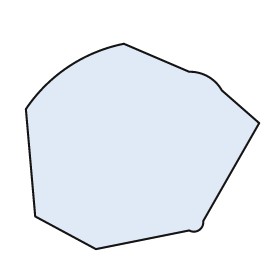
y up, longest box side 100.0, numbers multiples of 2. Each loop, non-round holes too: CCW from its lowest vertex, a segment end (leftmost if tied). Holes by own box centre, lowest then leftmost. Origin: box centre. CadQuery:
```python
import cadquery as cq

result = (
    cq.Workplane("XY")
    .moveTo(-20.0, -44.0)
    .lineTo(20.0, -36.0)
    .threePointArc((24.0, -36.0), (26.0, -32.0))
    .lineTo(50.0, 10.0)
    .lineTo(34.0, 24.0)
    .threePointArc((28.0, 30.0), (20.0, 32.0))
    .lineTo(-8.0, 44.0)
    .threePointArc((-32.0, 34.0), (-50.0, 16.0))
    .lineTo(-46.0, -30.0)
    .close()
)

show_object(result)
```